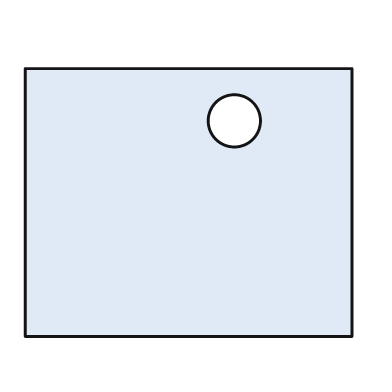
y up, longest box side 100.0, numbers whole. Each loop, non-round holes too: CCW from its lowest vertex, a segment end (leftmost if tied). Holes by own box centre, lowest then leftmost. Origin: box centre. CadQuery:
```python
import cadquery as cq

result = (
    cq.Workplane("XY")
    .moveTo(-50.0, -41.0)
    .lineTo(50.0, -41.0)
    .lineTo(50.0, 41.0)
    .lineTo(-50.0, 41.0)
    .close()
    .moveTo(14.0, 25.0)
    .circle(8.0)
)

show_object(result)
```